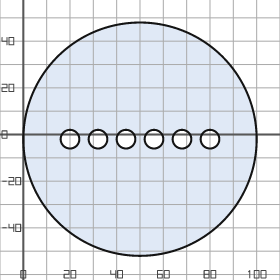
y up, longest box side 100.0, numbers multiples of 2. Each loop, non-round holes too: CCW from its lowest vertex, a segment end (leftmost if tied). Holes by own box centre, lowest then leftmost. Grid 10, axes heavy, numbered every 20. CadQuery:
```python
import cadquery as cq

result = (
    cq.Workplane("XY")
    .moveTo(50.0, -2.0)
    .circle(50.0)
    .moveTo(20.0, -2.0)
    .circle(4.0)
    .moveTo(32.0, -2.0)
    .circle(4.0)
    .moveTo(44.0, -2.0)
    .circle(4.0)
    .moveTo(56.0, -2.0)
    .circle(4.0)
    .moveTo(68.0, -2.0)
    .circle(4.0)
    .moveTo(80.0, -2.0)
    .circle(4.0)
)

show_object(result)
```